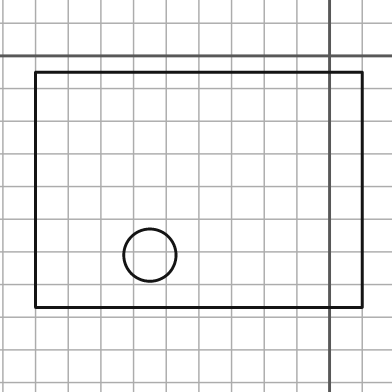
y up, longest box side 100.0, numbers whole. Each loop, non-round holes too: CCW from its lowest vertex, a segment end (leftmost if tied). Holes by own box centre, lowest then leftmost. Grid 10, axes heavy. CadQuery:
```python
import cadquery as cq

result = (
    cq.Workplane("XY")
    .moveTo(-90.0, -77.0)
    .lineTo(10.0, -77.0)
    .lineTo(10.0, -5.0)
    .lineTo(-90.0, -5.0)
    .close()
    .moveTo(-55.0, -61.0)
    .circle(8.0)
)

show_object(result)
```